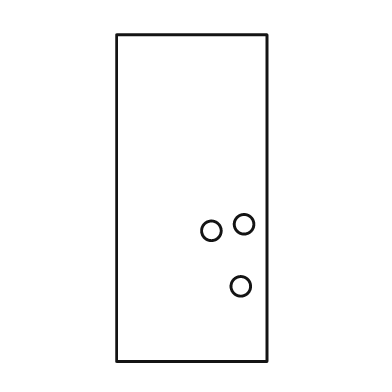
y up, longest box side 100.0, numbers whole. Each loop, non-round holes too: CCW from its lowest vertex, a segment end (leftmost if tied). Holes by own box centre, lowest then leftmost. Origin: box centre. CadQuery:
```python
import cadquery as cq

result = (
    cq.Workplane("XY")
    .moveTo(-23.0, -50.0)
    .lineTo(23.0, -50.0)
    .lineTo(23.0, 50.0)
    .lineTo(-23.0, 50.0)
    .close()
    .moveTo(15.0, -27.0)
    .circle(3.0)
    .moveTo(6.0, -10.0)
    .circle(3.0)
    .moveTo(16.0, -8.0)
    .circle(3.0)
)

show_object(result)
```